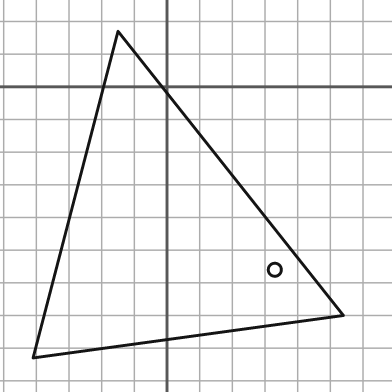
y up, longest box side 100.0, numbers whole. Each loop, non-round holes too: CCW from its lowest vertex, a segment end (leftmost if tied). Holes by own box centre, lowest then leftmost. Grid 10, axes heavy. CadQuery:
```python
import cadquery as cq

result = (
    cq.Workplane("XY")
    .moveTo(-41.0, -83.0)
    .lineTo(54.0, -70.0)
    .lineTo(-15.0, 17.0)
    .close()
    .moveTo(33.0, -56.0)
    .circle(2.0)
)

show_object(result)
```